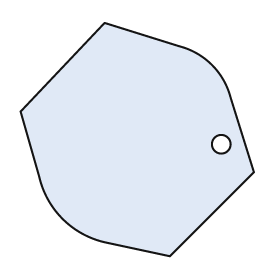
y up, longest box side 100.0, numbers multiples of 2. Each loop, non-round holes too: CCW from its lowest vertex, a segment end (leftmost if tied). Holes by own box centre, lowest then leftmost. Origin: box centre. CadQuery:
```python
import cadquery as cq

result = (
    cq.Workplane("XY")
    .moveTo(14.0, -50.0)
    .lineTo(50.0, -14.0)
    .lineTo(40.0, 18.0)
    .threePointArc((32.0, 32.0), (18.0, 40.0))
    .lineTo(-14.0, 50.0)
    .lineTo(-50.0, 12.0)
    .lineTo(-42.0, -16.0)
    .threePointArc((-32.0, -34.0), (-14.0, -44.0))
    .close()
    .moveTo(36.0, -2.0)
    .circle(4.0)
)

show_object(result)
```